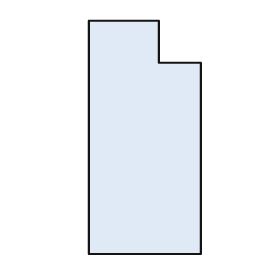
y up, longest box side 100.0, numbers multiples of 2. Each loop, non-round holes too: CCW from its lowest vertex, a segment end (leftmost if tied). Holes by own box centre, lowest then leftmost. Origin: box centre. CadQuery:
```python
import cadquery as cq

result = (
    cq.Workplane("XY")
    .moveTo(-24.0, -50.0)
    .lineTo(24.0, -50.0)
    .lineTo(24.0, 32.0)
    .lineTo(6.0, 32.0)
    .lineTo(6.0, 50.0)
    .lineTo(-24.0, 50.0)
    .close()
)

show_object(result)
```